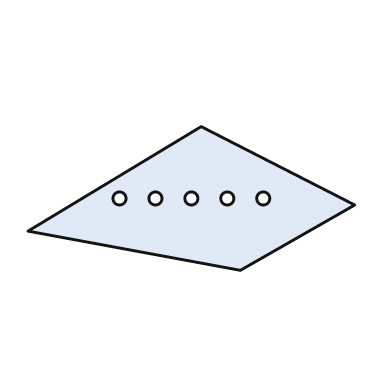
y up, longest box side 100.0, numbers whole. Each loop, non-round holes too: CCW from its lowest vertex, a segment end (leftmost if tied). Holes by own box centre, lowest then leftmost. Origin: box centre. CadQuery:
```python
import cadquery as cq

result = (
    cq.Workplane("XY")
    .moveTo(15.0, -22.0)
    .lineTo(50.0, -2.0)
    .lineTo(3.0, 22.0)
    .lineTo(-50.0, -10.0)
    .close()
    .moveTo(-22.0, 0.0)
    .circle(2.0)
    .moveTo(-11.0, 0.0)
    .circle(2.0)
    .moveTo(0.0, 0.0)
    .circle(2.0)
    .moveTo(11.0, 0.0)
    .circle(2.0)
    .moveTo(22.0, 0.0)
    .circle(2.0)
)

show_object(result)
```